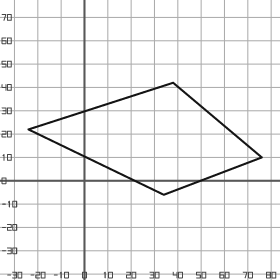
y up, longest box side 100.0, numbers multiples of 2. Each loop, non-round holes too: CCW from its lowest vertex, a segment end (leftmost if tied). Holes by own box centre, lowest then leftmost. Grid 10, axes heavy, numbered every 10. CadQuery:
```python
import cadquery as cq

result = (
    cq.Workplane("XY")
    .moveTo(34.0, -6.0)
    .lineTo(76.0, 10.0)
    .lineTo(38.0, 42.0)
    .lineTo(-24.0, 22.0)
    .close()
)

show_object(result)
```